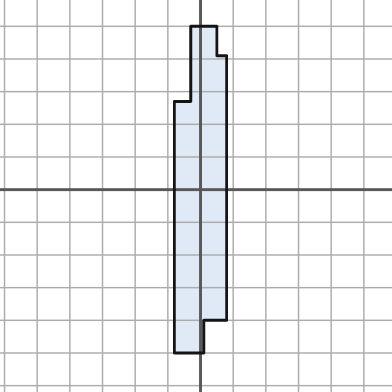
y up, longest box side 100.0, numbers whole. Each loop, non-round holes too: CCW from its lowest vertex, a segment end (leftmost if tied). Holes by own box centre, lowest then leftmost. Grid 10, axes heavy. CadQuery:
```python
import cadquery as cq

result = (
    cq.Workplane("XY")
    .moveTo(-8.0, -50.0)
    .lineTo(1.0, -50.0)
    .lineTo(1.0, -40.0)
    .lineTo(8.0, -40.0)
    .lineTo(8.0, 41.0)
    .lineTo(5.0, 41.0)
    .lineTo(5.0, 50.0)
    .lineTo(-3.0, 50.0)
    .lineTo(-3.0, 27.0)
    .lineTo(-8.0, 27.0)
    .close()
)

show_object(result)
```